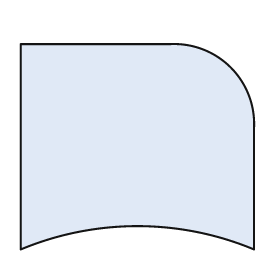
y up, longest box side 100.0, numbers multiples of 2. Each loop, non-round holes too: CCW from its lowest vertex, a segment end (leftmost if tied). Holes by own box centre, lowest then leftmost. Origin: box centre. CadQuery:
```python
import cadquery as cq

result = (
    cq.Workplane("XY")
    .moveTo(-50.0, -44.0)
    .threePointArc((0.0, -34.0), (50.0, -44.0))
    .lineTo(50.0, 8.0)
    .threePointArc((40.0, 34.0), (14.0, 44.0))
    .lineTo(-50.0, 44.0)
    .close()
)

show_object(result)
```